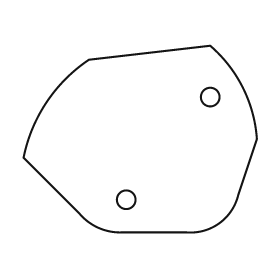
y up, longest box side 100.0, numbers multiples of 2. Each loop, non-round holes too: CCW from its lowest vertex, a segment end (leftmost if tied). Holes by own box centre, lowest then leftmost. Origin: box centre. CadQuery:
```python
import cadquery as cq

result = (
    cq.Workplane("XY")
    .moveTo(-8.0, -40.0)
    .lineTo(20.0, -40.0)
    .threePointArc((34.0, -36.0), (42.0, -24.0))
    .lineTo(50.0, 0.0)
    .threePointArc((44.0, 22.0), (30.0, 40.0))
    .lineTo(-22.0, 34.0)
    .threePointArc((-40.0, 16.0), (-50.0, -8.0))
    .lineTo(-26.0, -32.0)
    .threePointArc((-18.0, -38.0), (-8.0, -40.0))
    .close()
    .moveTo(-6.0, -26.0)
    .circle(4.0)
    .moveTo(30.0, 18.0)
    .circle(4.0)
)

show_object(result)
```